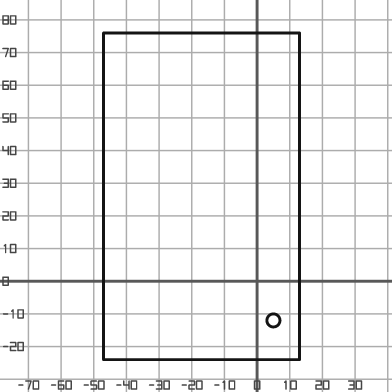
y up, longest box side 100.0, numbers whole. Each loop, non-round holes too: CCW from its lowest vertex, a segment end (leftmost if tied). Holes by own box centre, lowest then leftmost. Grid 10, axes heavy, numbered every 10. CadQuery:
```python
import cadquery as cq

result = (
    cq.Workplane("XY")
    .moveTo(-47.0, -24.0)
    .lineTo(13.0, -24.0)
    .lineTo(13.0, 76.0)
    .lineTo(-47.0, 76.0)
    .close()
    .moveTo(5.0, -12.0)
    .circle(2.0)
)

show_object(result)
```